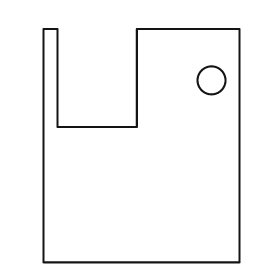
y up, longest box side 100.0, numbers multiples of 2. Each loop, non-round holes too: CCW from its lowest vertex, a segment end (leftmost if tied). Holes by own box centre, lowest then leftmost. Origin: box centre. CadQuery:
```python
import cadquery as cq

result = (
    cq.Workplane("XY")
    .moveTo(-42.0, -50.0)
    .lineTo(42.0, -50.0)
    .lineTo(42.0, 50.0)
    .lineTo(-2.0, 50.0)
    .lineTo(-2.0, 8.0)
    .lineTo(-36.0, 8.0)
    .lineTo(-36.0, 50.0)
    .lineTo(-42.0, 50.0)
    .close()
    .moveTo(30.0, 28.0)
    .circle(6.0)
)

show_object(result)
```